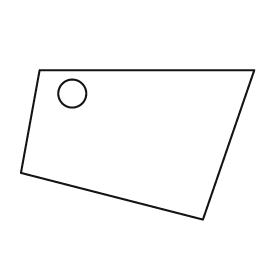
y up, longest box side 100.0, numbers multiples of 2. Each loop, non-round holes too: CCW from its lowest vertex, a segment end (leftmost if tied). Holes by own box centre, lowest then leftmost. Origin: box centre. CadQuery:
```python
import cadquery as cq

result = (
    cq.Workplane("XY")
    .moveTo(28.0, -32.0)
    .lineTo(50.0, 32.0)
    .lineTo(-42.0, 32.0)
    .lineTo(-50.0, -12.0)
    .close()
    .moveTo(-28.0, 22.0)
    .circle(6.0)
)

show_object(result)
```